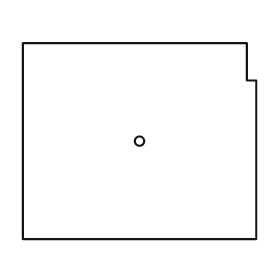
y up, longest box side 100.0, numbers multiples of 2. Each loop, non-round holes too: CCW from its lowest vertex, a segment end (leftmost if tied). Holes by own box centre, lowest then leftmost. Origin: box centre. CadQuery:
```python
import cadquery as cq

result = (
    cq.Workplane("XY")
    .moveTo(-50.0, -42.0)
    .lineTo(50.0, -42.0)
    .lineTo(50.0, 26.0)
    .lineTo(46.0, 26.0)
    .lineTo(46.0, 42.0)
    .lineTo(-50.0, 42.0)
    .close()
    .moveTo(0.0, 0.0)
    .circle(2.0)
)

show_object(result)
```